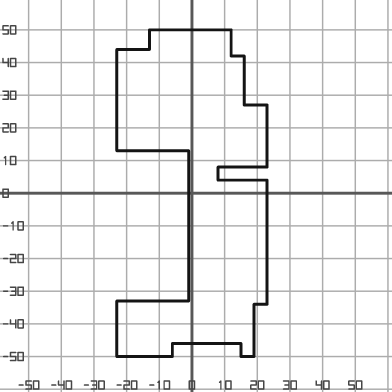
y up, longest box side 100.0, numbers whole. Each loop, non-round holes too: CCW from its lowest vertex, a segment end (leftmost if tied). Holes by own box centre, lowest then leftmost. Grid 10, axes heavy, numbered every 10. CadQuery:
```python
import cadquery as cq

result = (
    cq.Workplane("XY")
    .moveTo(-23.0, -50.0)
    .lineTo(-6.0, -50.0)
    .lineTo(-6.0, -46.0)
    .lineTo(15.0, -46.0)
    .lineTo(15.0, -50.0)
    .lineTo(19.0, -50.0)
    .lineTo(19.0, -34.0)
    .lineTo(23.0, -34.0)
    .lineTo(23.0, 4.0)
    .lineTo(8.0, 4.0)
    .lineTo(8.0, 8.0)
    .lineTo(23.0, 8.0)
    .lineTo(23.0, 27.0)
    .lineTo(16.0, 27.0)
    .lineTo(16.0, 42.0)
    .lineTo(12.0, 42.0)
    .lineTo(12.0, 50.0)
    .lineTo(-13.0, 50.0)
    .lineTo(-13.0, 44.0)
    .lineTo(-23.0, 44.0)
    .lineTo(-23.0, 13.0)
    .lineTo(-1.0, 13.0)
    .lineTo(-1.0, -33.0)
    .lineTo(-23.0, -33.0)
    .close()
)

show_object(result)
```